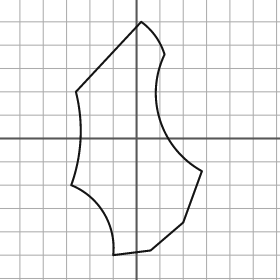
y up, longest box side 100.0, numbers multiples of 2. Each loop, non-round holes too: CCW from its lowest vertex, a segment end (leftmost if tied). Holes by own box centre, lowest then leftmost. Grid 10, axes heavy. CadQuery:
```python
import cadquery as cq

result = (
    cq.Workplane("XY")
    .moveTo(-10.0, -50.0)
    .lineTo(6.0, -48.0)
    .lineTo(20.0, -36.0)
    .lineTo(28.0, -14.0)
    .threePointArc((10.0, 8.0), (12.0, 36.0))
    .threePointArc((8.0, 44.0), (2.0, 50.0))
    .lineTo(-26.0, 20.0)
    .threePointArc((-24.0, 0.0), (-28.0, -20.0))
    .threePointArc((-14.0, -32.0), (-10.0, -50.0))
    .close()
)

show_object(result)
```